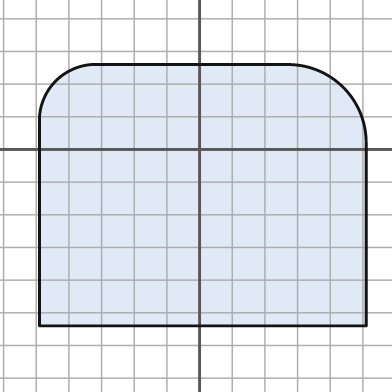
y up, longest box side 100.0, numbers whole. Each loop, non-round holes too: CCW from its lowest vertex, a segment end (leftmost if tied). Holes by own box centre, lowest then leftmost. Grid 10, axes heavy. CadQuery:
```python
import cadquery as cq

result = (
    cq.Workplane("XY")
    .moveTo(-49.0, -54.0)
    .lineTo(51.0, -54.0)
    .lineTo(51.0, 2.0)
    .threePointArc((44.0, 19.0), (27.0, 26.0))
    .lineTo(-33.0, 26.0)
    .threePointArc((-44.0, 21.0), (-49.0, 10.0))
    .close()
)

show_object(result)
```